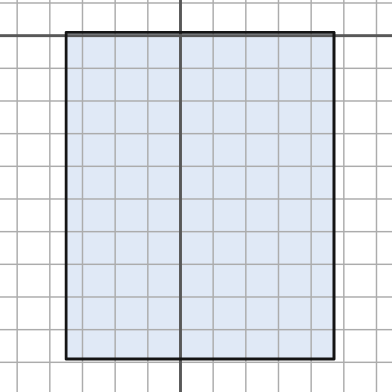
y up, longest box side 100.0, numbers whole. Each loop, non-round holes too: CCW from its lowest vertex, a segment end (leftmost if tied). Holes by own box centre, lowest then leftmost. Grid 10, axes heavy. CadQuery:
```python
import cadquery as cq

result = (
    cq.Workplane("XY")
    .moveTo(-35.0, -99.0)
    .lineTo(47.0, -99.0)
    .lineTo(47.0, 1.0)
    .lineTo(-35.0, 1.0)
    .close()
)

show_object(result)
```